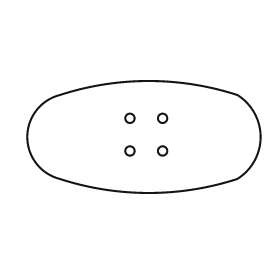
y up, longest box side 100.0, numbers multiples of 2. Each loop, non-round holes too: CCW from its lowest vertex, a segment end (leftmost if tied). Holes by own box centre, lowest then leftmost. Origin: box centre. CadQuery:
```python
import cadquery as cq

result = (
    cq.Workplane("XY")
    .moveTo(-36.0, -18.0)
    .threePointArc((2.0, -24.0), (40.0, -18.0))
    .threePointArc((50.0, 0.0), (40.0, 18.0))
    .threePointArc((2.0, 24.0), (-36.0, 18.0))
    .threePointArc((-50.0, 0.0), (-36.0, -18.0))
    .close()
    .moveTo(-6.0, -6.0)
    .circle(2.0)
    .moveTo(8.0, -6.0)
    .circle(2.0)
    .moveTo(-6.0, 8.0)
    .circle(2.0)
    .moveTo(8.0, 8.0)
    .circle(2.0)
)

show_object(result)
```